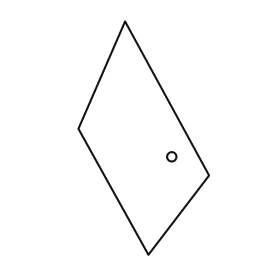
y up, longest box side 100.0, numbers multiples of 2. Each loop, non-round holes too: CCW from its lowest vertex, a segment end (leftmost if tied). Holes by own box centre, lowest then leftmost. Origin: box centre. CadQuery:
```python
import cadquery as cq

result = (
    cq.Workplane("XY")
    .moveTo(2.0, -50.0)
    .lineTo(28.0, -16.0)
    .lineTo(-8.0, 50.0)
    .lineTo(-28.0, 4.0)
    .close()
    .moveTo(12.0, -8.0)
    .circle(2.0)
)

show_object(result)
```